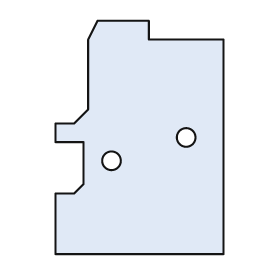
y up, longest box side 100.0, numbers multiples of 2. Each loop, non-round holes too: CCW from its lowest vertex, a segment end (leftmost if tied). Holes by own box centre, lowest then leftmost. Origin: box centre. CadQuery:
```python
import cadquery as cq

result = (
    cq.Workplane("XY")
    .moveTo(-36.0, -50.0)
    .lineTo(36.0, -50.0)
    .lineTo(36.0, 42.0)
    .lineTo(4.0, 42.0)
    .lineTo(4.0, 50.0)
    .lineTo(-18.0, 50.0)
    .lineTo(-22.0, 42.0)
    .lineTo(-22.0, 12.0)
    .lineTo(-28.0, 6.0)
    .lineTo(-36.0, 6.0)
    .lineTo(-36.0, -2.0)
    .lineTo(-24.0, -2.0)
    .lineTo(-24.0, -20.0)
    .lineTo(-28.0, -24.0)
    .lineTo(-36.0, -24.0)
    .close()
    .moveTo(-12.0, -10.0)
    .circle(4.0)
    .moveTo(20.0, 0.0)
    .circle(4.0)
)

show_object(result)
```